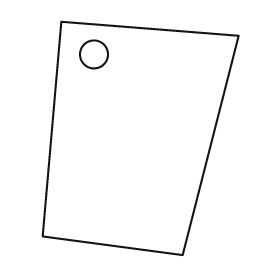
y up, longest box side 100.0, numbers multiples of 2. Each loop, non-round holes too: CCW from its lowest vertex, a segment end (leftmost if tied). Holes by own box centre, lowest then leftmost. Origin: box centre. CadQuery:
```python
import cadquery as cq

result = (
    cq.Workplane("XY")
    .moveTo(18.0, -50.0)
    .lineTo(42.0, 44.0)
    .lineTo(-34.0, 50.0)
    .lineTo(-42.0, -42.0)
    .close()
    .moveTo(-20.0, 36.0)
    .circle(6.0)
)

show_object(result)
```